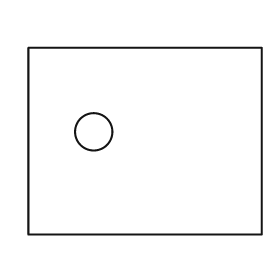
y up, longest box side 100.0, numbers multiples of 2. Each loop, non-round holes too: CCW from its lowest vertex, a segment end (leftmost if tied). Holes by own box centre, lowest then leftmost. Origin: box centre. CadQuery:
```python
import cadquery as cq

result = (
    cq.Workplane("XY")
    .moveTo(-50.0, -40.0)
    .lineTo(50.0, -40.0)
    .lineTo(50.0, 40.0)
    .lineTo(-50.0, 40.0)
    .close()
    .moveTo(-22.0, 4.0)
    .circle(8.0)
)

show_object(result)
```